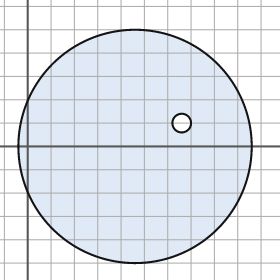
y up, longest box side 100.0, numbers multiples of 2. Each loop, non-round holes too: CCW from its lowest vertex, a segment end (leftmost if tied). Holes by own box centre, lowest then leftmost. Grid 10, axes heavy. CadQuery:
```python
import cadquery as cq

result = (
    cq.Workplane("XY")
    .moveTo(46.0, 0.0)
    .circle(50.0)
    .moveTo(66.0, 10.0)
    .circle(4.0)
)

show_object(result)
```